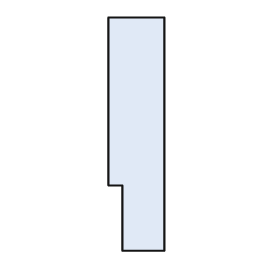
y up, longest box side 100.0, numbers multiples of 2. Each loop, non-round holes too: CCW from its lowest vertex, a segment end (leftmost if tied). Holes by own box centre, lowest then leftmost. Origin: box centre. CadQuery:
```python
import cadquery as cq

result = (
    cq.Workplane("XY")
    .moveTo(-6.0, -50.0)
    .lineTo(12.0, -50.0)
    .lineTo(12.0, 50.0)
    .lineTo(-12.0, 50.0)
    .lineTo(-12.0, -22.0)
    .lineTo(-6.0, -22.0)
    .close()
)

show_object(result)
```